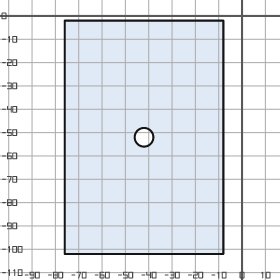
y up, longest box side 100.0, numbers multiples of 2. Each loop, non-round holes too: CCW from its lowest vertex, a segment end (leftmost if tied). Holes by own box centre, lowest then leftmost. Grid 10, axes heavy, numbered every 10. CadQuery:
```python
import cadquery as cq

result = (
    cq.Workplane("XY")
    .moveTo(-76.0, -102.0)
    .lineTo(-8.0, -102.0)
    .lineTo(-8.0, -2.0)
    .lineTo(-76.0, -2.0)
    .close()
    .moveTo(-42.0, -52.0)
    .circle(4.0)
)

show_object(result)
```